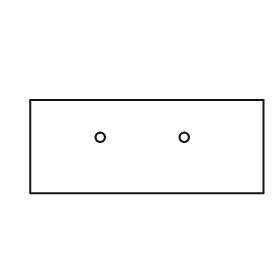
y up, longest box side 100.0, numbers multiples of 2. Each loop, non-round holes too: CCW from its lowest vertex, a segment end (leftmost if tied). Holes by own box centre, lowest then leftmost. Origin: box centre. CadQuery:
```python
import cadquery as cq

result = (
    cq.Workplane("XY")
    .moveTo(-50.0, -20.0)
    .lineTo(50.0, -20.0)
    .lineTo(50.0, 20.0)
    .lineTo(-50.0, 20.0)
    .close()
    .moveTo(-20.0, 4.0)
    .circle(2.0)
    .moveTo(16.0, 4.0)
    .circle(2.0)
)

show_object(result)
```